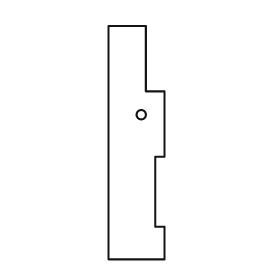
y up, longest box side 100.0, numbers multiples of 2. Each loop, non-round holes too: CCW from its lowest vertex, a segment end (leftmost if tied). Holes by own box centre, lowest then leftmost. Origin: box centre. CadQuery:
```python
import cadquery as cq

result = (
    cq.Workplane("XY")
    .moveTo(-12.0, -50.0)
    .lineTo(12.0, -50.0)
    .lineTo(12.0, -36.0)
    .lineTo(8.0, -36.0)
    .lineTo(8.0, -6.0)
    .lineTo(12.0, -6.0)
    .lineTo(12.0, 22.0)
    .lineTo(4.0, 22.0)
    .lineTo(4.0, 50.0)
    .lineTo(-12.0, 50.0)
    .close()
    .moveTo(2.0, 12.0)
    .circle(2.0)
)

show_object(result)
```